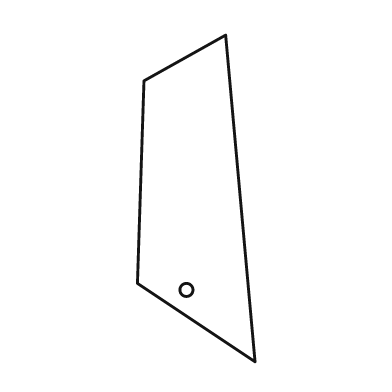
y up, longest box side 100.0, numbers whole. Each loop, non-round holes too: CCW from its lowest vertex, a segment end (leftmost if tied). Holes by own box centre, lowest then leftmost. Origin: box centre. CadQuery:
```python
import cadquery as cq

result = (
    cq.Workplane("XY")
    .moveTo(18.0, -50.0)
    .lineTo(9.0, 50.0)
    .lineTo(-16.0, 36.0)
    .lineTo(-18.0, -26.0)
    .close()
    .moveTo(-3.0, -28.0)
    .circle(2.0)
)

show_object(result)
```